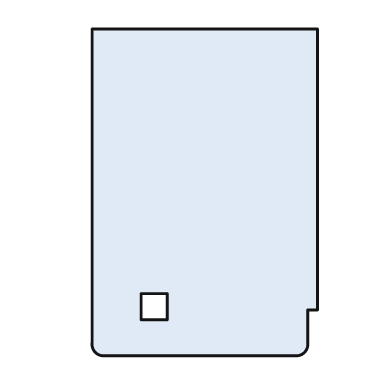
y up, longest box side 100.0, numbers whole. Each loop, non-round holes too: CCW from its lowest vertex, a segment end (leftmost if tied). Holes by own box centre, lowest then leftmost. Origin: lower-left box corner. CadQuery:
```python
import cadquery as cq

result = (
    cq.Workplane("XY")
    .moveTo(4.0, 0.0)
    .lineTo(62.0, 0.0)
    .threePointArc((65.0, 1.0), (66.0, 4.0))
    .lineTo(66.0, 14.0)
    .lineTo(69.0, 14.0)
    .lineTo(69.0, 100.0)
    .lineTo(0.0, 100.0)
    .lineTo(0.0, 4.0)
    .threePointArc((1.0, 1.0), (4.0, 0.0))
    .close()
    .moveTo(15.0, 11.0)
    .lineTo(23.0, 11.0)
    .lineTo(23.0, 19.0)
    .lineTo(15.0, 19.0)
    .close()
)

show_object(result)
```